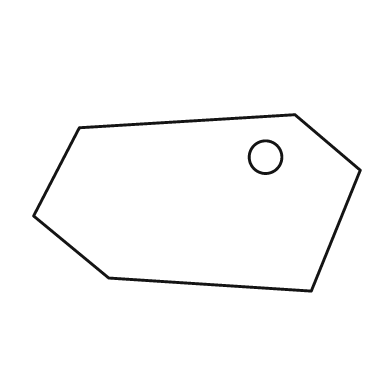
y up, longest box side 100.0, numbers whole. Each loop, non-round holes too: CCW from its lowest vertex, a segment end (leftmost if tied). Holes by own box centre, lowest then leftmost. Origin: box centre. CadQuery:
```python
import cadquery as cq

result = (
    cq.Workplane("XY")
    .moveTo(35.0, -27.0)
    .lineTo(50.0, 10.0)
    .lineTo(30.0, 27.0)
    .lineTo(-36.0, 23.0)
    .lineTo(-50.0, -4.0)
    .lineTo(-27.0, -23.0)
    .close()
    .moveTo(21.0, 14.0)
    .circle(5.0)
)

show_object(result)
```